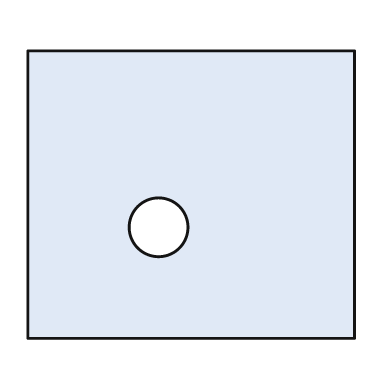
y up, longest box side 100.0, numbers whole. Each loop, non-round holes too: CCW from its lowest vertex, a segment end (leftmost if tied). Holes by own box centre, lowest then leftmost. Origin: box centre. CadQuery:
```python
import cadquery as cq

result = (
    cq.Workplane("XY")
    .moveTo(-50.0, -44.0)
    .lineTo(50.0, -44.0)
    .lineTo(50.0, 44.0)
    .lineTo(-50.0, 44.0)
    .close()
    .moveTo(-10.0, -10.0)
    .circle(9.0)
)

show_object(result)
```